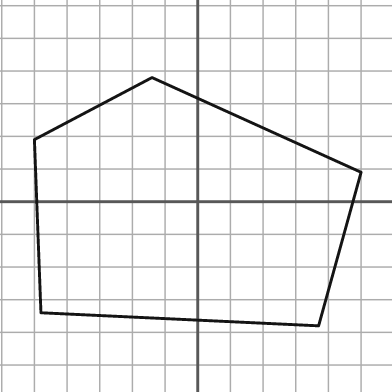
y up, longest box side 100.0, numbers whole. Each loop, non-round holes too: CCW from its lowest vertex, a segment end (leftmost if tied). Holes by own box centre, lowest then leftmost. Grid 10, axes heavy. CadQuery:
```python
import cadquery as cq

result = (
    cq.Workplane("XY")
    .moveTo(37.0, -38.0)
    .lineTo(50.0, 9.0)
    .lineTo(-14.0, 38.0)
    .lineTo(-50.0, 19.0)
    .lineTo(-48.0, -34.0)
    .close()
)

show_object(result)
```